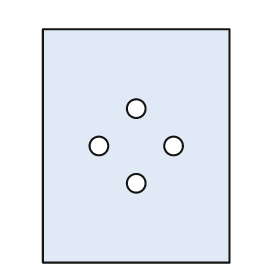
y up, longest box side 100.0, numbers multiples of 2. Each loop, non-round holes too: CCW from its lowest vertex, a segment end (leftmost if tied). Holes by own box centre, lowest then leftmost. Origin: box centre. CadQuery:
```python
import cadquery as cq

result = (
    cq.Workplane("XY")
    .moveTo(-40.0, -50.0)
    .lineTo(40.0, -50.0)
    .lineTo(40.0, 50.0)
    .lineTo(-40.0, 50.0)
    .close()
    .moveTo(0.0, -16.0)
    .circle(4.0)
    .moveTo(-16.0, 0.0)
    .circle(4.0)
    .moveTo(16.0, 0.0)
    .circle(4.0)
    .moveTo(0.0, 16.0)
    .circle(4.0)
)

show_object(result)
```